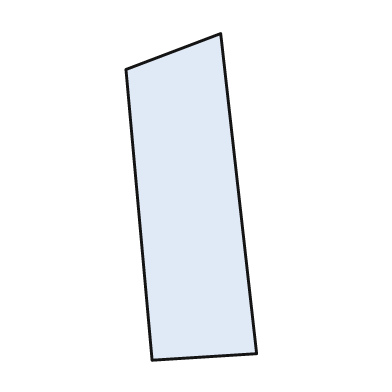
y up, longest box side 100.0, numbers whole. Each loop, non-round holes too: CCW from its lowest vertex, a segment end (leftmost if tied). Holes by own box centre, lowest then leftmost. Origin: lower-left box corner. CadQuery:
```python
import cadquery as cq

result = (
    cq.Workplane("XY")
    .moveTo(8.0, 0.0)
    .lineTo(40.0, 2.0)
    .lineTo(29.0, 100.0)
    .lineTo(0.0, 89.0)
    .close()
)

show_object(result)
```